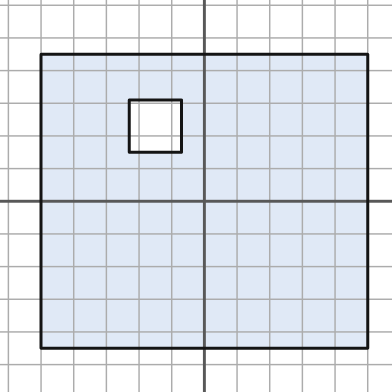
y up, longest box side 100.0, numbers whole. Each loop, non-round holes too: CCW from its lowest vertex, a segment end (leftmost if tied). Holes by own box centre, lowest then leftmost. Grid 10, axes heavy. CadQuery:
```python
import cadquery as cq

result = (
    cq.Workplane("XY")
    .moveTo(-50.0, -45.0)
    .lineTo(50.0, -45.0)
    .lineTo(50.0, 45.0)
    .lineTo(-50.0, 45.0)
    .close()
    .moveTo(-23.0, 15.0)
    .lineTo(-7.0, 15.0)
    .lineTo(-7.0, 31.0)
    .lineTo(-23.0, 31.0)
    .close()
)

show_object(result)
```